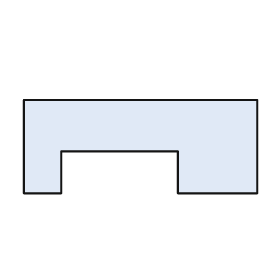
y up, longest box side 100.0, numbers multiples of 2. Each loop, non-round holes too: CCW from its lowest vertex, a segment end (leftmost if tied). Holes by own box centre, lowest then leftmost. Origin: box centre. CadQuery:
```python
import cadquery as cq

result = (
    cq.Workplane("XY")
    .moveTo(-50.0, -20.0)
    .lineTo(-34.0, -20.0)
    .lineTo(-34.0, -2.0)
    .lineTo(16.0, -2.0)
    .lineTo(16.0, -20.0)
    .lineTo(50.0, -20.0)
    .lineTo(50.0, 20.0)
    .lineTo(-50.0, 20.0)
    .close()
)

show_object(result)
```